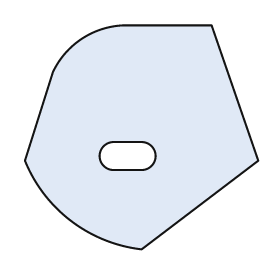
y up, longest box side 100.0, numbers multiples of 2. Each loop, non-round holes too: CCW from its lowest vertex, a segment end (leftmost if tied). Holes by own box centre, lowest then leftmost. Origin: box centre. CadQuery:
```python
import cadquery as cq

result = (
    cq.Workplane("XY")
    .moveTo(0.0, -48.0)
    .lineTo(50.0, -10.0)
    .lineTo(30.0, 48.0)
    .lineTo(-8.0, 48.0)
    .threePointArc((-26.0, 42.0), (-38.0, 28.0))
    .lineTo(-50.0, -10.0)
    .threePointArc((-30.0, -36.0), (0.0, -48.0))
    .close()
    .moveTo(-12.0, -14.0)
    .lineTo(0.0, -14.0)
    .threePointArc((6.0, -8.0), (0.0, -2.0))
    .lineTo(-12.0, -2.0)
    .threePointArc((-18.0, -8.0), (-12.0, -14.0))
    .close()
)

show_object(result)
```